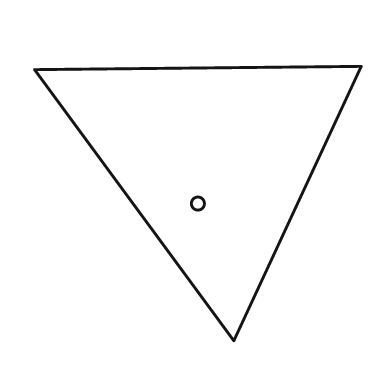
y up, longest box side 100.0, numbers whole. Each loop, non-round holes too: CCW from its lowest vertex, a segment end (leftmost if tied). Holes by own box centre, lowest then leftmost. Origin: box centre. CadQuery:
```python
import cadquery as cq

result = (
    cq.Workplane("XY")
    .moveTo(11.0, -42.0)
    .lineTo(50.0, 42.0)
    .lineTo(-50.0, 41.0)
    .close()
    .moveTo(0.0, 0.0)
    .circle(2.0)
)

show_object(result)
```